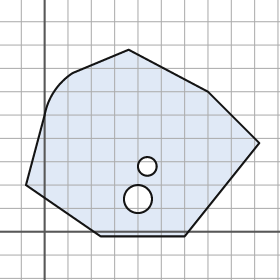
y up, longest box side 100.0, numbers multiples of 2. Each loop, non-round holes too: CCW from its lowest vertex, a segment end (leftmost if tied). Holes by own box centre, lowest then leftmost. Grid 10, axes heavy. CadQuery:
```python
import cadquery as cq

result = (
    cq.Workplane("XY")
    .moveTo(24.0, -2.0)
    .lineTo(60.0, -2.0)
    .lineTo(92.0, 38.0)
    .lineTo(70.0, 60.0)
    .lineTo(36.0, 78.0)
    .lineTo(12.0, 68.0)
    .threePointArc((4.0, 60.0), (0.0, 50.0))
    .lineTo(-8.0, 20.0)
    .close()
    .moveTo(40.0, 14.0)
    .circle(6.0)
    .moveTo(44.0, 28.0)
    .circle(4.0)
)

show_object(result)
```